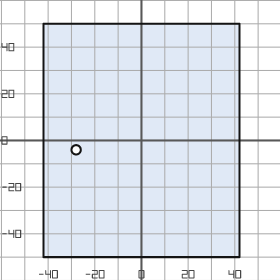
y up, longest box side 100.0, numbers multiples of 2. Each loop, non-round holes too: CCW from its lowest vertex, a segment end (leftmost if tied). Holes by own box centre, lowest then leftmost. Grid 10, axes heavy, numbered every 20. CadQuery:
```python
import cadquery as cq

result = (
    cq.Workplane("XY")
    .moveTo(-42.0, -50.0)
    .lineTo(42.0, -50.0)
    .lineTo(42.0, 50.0)
    .lineTo(-42.0, 50.0)
    .close()
    .moveTo(-28.0, -4.0)
    .circle(2.0)
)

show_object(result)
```